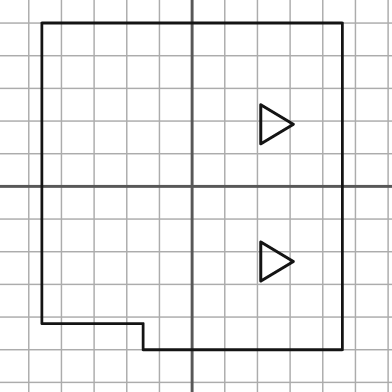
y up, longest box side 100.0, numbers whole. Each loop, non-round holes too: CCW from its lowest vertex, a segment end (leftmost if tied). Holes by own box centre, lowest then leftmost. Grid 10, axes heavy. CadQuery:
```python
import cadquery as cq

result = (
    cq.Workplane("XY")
    .moveTo(-15.0, -50.0)
    .lineTo(46.0, -50.0)
    .lineTo(46.0, 50.0)
    .lineTo(-46.0, 50.0)
    .lineTo(-46.0, -42.0)
    .lineTo(-15.0, -42.0)
    .close()
    .moveTo(21.0, -29.0)
    .lineTo(31.0, -23.0)
    .lineTo(21.0, -17.0)
    .close()
    .moveTo(21.0, 13.0)
    .lineTo(31.0, 19.0)
    .lineTo(21.0, 25.0)
    .close()
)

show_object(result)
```